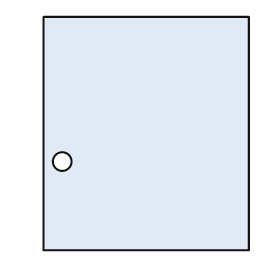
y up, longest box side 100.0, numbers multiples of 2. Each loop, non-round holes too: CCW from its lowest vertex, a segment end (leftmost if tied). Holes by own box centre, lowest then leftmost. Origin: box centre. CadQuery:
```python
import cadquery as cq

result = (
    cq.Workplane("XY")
    .moveTo(-44.0, -50.0)
    .lineTo(44.0, -50.0)
    .lineTo(44.0, 50.0)
    .lineTo(-44.0, 50.0)
    .close()
    .moveTo(-36.0, -12.0)
    .circle(4.0)
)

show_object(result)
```